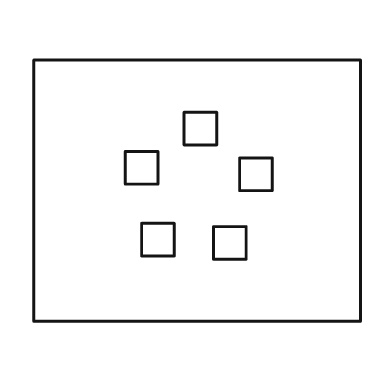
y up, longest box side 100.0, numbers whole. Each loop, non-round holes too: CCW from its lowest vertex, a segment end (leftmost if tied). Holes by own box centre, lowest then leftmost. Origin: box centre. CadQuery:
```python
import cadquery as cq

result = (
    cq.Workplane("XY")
    .moveTo(-50.0, -40.0)
    .lineTo(50.0, -40.0)
    .lineTo(50.0, 40.0)
    .lineTo(-50.0, 40.0)
    .close()
    .moveTo(5.0, -21.0)
    .lineTo(15.0, -21.0)
    .lineTo(15.0, -11.0)
    .lineTo(5.0, -11.0)
    .close()
    .moveTo(-17.0, -20.0)
    .lineTo(-7.0, -20.0)
    .lineTo(-7.0, -10.0)
    .lineTo(-17.0, -10.0)
    .close()
    .moveTo(13.0, 0.0)
    .lineTo(23.0, 0.0)
    .lineTo(23.0, 10.0)
    .lineTo(13.0, 10.0)
    .close()
    .moveTo(-22.0, 2.0)
    .lineTo(-12.0, 2.0)
    .lineTo(-12.0, 12.0)
    .lineTo(-22.0, 12.0)
    .close()
    .moveTo(-4.0, 14.0)
    .lineTo(6.0, 14.0)
    .lineTo(6.0, 24.0)
    .lineTo(-4.0, 24.0)
    .close()
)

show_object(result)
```